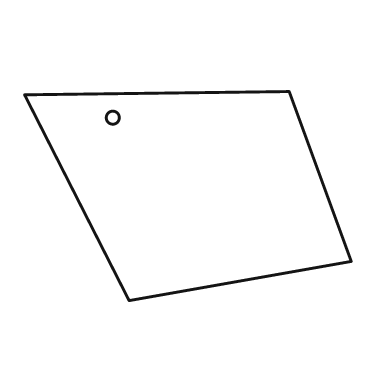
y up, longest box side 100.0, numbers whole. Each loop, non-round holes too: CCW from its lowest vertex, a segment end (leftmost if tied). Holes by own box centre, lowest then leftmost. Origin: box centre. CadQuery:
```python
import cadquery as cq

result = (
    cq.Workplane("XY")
    .moveTo(-18.0, -32.0)
    .lineTo(50.0, -20.0)
    .lineTo(31.0, 32.0)
    .lineTo(-50.0, 31.0)
    .close()
    .moveTo(-23.0, 24.0)
    .circle(2.0)
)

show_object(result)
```